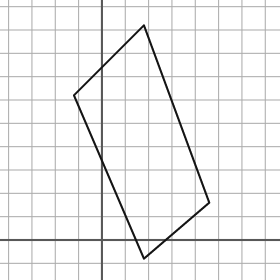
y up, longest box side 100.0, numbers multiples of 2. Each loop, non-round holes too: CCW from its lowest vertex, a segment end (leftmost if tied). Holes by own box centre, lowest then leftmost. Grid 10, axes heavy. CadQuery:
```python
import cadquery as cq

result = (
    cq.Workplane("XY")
    .moveTo(18.0, -8.0)
    .lineTo(46.0, 16.0)
    .lineTo(18.0, 92.0)
    .lineTo(-12.0, 62.0)
    .close()
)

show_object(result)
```